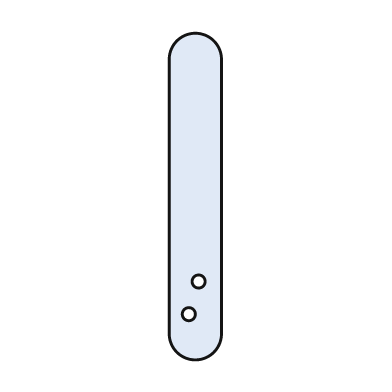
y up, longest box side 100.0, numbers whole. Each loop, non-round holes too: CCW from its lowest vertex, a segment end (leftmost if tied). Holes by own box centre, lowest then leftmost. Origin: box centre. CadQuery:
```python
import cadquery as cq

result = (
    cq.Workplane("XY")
    .moveTo(-8.0, -42.0)
    .threePointArc((0.0, -50.0), (8.0, -42.0))
    .lineTo(8.0, 42.0)
    .threePointArc((0.0, 50.0), (-8.0, 42.0))
    .close()
    .moveTo(-2.0, -36.0)
    .circle(2.0)
    .moveTo(1.0, -26.0)
    .circle(2.0)
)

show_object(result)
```